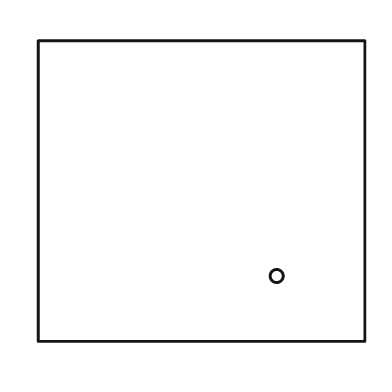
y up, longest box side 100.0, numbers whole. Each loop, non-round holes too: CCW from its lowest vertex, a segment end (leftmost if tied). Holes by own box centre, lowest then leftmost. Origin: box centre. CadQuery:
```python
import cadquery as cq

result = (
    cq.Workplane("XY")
    .moveTo(-50.0, -46.0)
    .lineTo(50.0, -46.0)
    .lineTo(50.0, 46.0)
    .lineTo(-50.0, 46.0)
    .close()
    .moveTo(23.0, -26.0)
    .circle(2.0)
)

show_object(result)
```